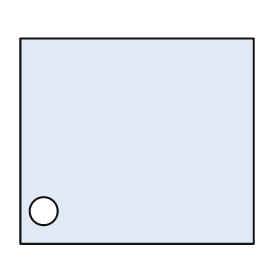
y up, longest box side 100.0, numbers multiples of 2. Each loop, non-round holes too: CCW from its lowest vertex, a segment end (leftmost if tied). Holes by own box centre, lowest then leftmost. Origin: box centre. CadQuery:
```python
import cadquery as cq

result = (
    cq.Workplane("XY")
    .moveTo(-50.0, -44.0)
    .lineTo(50.0, -44.0)
    .lineTo(50.0, 44.0)
    .lineTo(-50.0, 44.0)
    .close()
    .moveTo(-40.0, -30.0)
    .circle(6.0)
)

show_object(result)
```